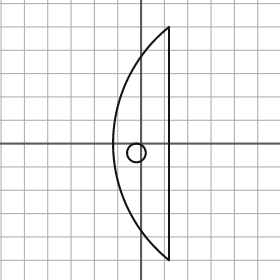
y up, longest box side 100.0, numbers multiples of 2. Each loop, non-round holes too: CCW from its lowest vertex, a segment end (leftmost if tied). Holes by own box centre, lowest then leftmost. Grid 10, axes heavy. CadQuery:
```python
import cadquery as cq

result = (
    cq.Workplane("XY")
    .moveTo(12.0, -50.0)
    .lineTo(12.0, 50.0)
    .threePointArc((-12.0, 0.0), (12.0, -50.0))
    .close()
    .moveTo(-2.0, -4.0)
    .circle(4.0)
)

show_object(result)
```